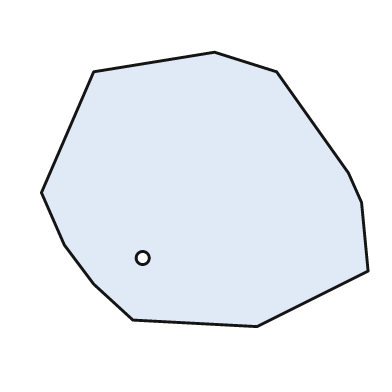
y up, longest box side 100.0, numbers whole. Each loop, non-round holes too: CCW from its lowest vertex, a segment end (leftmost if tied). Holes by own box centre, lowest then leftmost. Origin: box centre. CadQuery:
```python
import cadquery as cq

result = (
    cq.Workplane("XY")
    .moveTo(16.0, -42.0)
    .lineTo(50.0, -25.0)
    .lineTo(48.0, -4.0)
    .lineTo(44.0, 5.0)
    .lineTo(22.0, 36.0)
    .lineTo(3.0, 42.0)
    .lineTo(-34.0, 36.0)
    .lineTo(-50.0, -1.0)
    .lineTo(-43.0, -17.0)
    .lineTo(-34.0, -29.0)
    .lineTo(-22.0, -40.0)
    .close()
    .moveTo(-19.0, -21.0)
    .circle(2.0)
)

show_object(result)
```